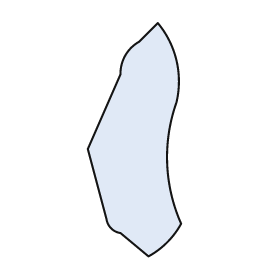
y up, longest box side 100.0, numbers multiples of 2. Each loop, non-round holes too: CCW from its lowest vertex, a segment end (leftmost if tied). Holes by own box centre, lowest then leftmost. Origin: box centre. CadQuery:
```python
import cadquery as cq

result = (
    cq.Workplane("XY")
    .moveTo(6.0, -50.0)
    .threePointArc((14.0, -44.0), (20.0, -36.0))
    .threePointArc((14.0, -10.0), (18.0, 16.0))
    .threePointArc((18.0, 34.0), (10.0, 50.0))
    .lineTo(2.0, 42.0)
    .threePointArc((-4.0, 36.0), (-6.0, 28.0))
    .lineTo(-20.0, -4.0)
    .lineTo(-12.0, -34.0)
    .threePointArc((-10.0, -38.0), (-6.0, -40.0))
    .close()
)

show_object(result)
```